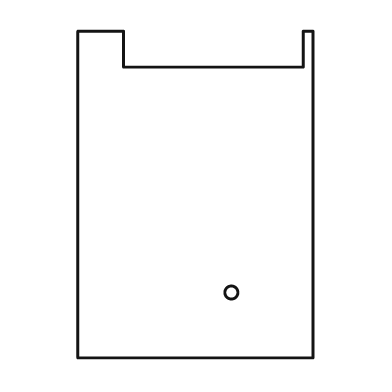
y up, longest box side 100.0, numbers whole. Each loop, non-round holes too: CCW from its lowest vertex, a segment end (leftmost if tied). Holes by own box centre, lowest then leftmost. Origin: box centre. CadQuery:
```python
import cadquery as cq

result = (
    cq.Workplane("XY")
    .moveTo(-36.0, -50.0)
    .lineTo(36.0, -50.0)
    .lineTo(36.0, 50.0)
    .lineTo(33.0, 50.0)
    .lineTo(33.0, 39.0)
    .lineTo(-22.0, 39.0)
    .lineTo(-22.0, 50.0)
    .lineTo(-36.0, 50.0)
    .close()
    .moveTo(11.0, -30.0)
    .circle(2.0)
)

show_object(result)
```